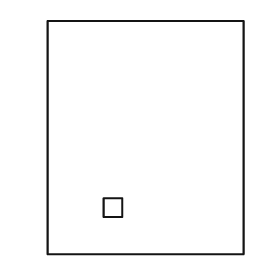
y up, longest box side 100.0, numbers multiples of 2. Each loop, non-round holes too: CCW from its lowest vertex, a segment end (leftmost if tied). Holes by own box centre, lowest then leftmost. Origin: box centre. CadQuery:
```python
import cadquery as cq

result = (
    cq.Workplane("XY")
    .moveTo(-42.0, -50.0)
    .lineTo(42.0, -50.0)
    .lineTo(42.0, 50.0)
    .lineTo(-42.0, 50.0)
    .close()
    .moveTo(-18.0, -34.0)
    .lineTo(-10.0, -34.0)
    .lineTo(-10.0, -26.0)
    .lineTo(-18.0, -26.0)
    .close()
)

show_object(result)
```